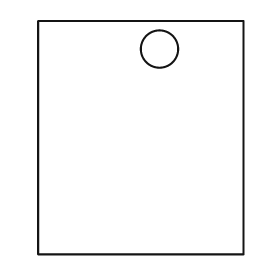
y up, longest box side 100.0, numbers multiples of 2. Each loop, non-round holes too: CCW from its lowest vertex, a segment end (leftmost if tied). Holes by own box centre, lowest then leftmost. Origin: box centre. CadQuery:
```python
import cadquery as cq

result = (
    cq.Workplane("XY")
    .moveTo(-44.0, -50.0)
    .lineTo(44.0, -50.0)
    .lineTo(44.0, 50.0)
    .lineTo(-44.0, 50.0)
    .close()
    .moveTo(8.0, 38.0)
    .circle(8.0)
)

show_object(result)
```